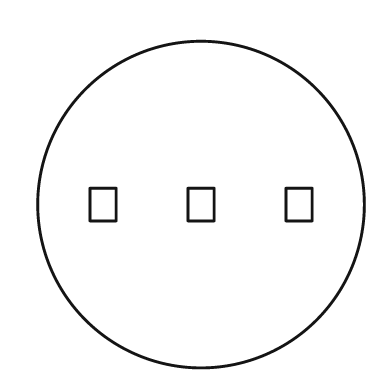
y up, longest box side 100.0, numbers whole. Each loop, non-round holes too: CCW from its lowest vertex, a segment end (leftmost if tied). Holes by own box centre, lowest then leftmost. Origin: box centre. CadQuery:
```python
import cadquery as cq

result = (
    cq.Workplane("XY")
    .moveTo(0.0, 0.0)
    .circle(50.0)
    .moveTo(-34.0, -5.0)
    .lineTo(-26.0, -5.0)
    .lineTo(-26.0, 5.0)
    .lineTo(-34.0, 5.0)
    .close()
    .moveTo(-4.0, -5.0)
    .lineTo(4.0, -5.0)
    .lineTo(4.0, 5.0)
    .lineTo(-4.0, 5.0)
    .close()
    .moveTo(26.0, -5.0)
    .lineTo(34.0, -5.0)
    .lineTo(34.0, 5.0)
    .lineTo(26.0, 5.0)
    .close()
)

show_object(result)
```